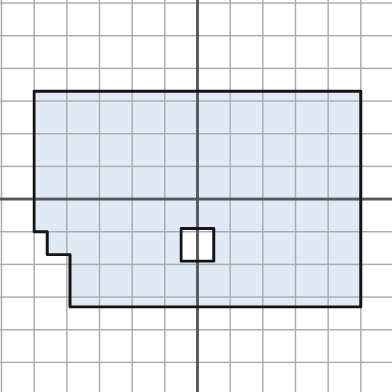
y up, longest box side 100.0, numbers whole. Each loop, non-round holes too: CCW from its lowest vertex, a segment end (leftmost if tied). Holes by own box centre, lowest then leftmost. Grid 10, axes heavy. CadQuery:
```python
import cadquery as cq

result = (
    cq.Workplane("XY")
    .moveTo(-39.0, -33.0)
    .lineTo(50.0, -33.0)
    .lineTo(50.0, 33.0)
    .lineTo(-50.0, 33.0)
    .lineTo(-50.0, -10.0)
    .lineTo(-46.0, -10.0)
    .lineTo(-46.0, -17.0)
    .lineTo(-39.0, -17.0)
    .close()
    .moveTo(-5.0, -19.0)
    .lineTo(5.0, -19.0)
    .lineTo(5.0, -9.0)
    .lineTo(-5.0, -9.0)
    .close()
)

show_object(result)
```